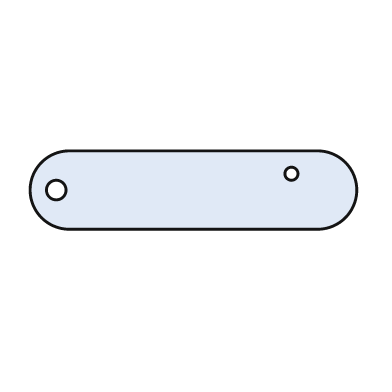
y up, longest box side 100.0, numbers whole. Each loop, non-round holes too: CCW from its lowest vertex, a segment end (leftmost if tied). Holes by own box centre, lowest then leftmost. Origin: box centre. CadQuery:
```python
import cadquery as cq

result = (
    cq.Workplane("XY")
    .moveTo(-38.0, -12.0)
    .lineTo(38.0, -12.0)
    .threePointArc((50.0, 0.0), (38.0, 12.0))
    .lineTo(-38.0, 12.0)
    .threePointArc((-50.0, 0.0), (-38.0, -12.0))
    .close()
    .moveTo(-42.0, 0.0)
    .circle(3.0)
    .moveTo(30.0, 5.0)
    .circle(2.0)
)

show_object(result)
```